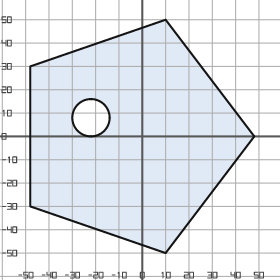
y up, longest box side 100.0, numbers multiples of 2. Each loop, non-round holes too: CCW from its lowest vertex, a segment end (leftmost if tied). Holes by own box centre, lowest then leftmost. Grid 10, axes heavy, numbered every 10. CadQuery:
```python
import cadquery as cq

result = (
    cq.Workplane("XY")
    .moveTo(10.0, -50.0)
    .lineTo(48.0, 0.0)
    .lineTo(10.0, 50.0)
    .lineTo(-48.0, 30.0)
    .lineTo(-48.0, -30.0)
    .close()
    .moveTo(-22.0, 8.0)
    .circle(8.0)
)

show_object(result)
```